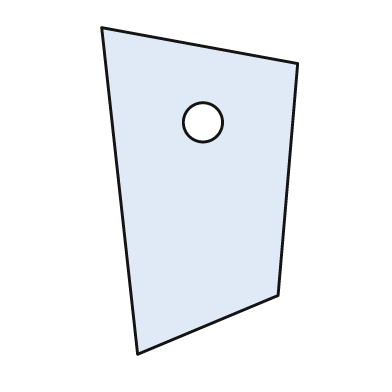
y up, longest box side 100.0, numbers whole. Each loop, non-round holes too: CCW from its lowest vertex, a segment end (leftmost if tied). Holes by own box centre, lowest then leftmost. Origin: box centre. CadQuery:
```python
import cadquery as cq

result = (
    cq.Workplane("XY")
    .moveTo(-19.0, -50.0)
    .lineTo(24.0, -32.0)
    .lineTo(30.0, 39.0)
    .lineTo(-30.0, 50.0)
    .close()
    .moveTo(1.0, 21.0)
    .circle(6.0)
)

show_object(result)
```